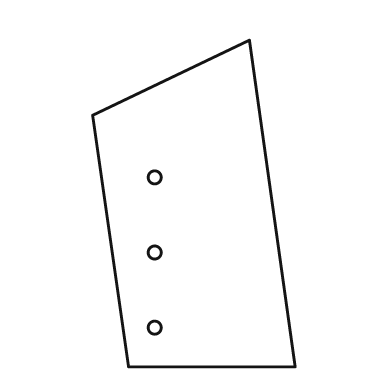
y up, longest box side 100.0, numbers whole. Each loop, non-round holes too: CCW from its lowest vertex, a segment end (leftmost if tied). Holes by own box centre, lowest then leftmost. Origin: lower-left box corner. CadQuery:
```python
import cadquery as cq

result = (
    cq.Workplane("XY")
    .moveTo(11.0, 0.0)
    .lineTo(62.0, 0.0)
    .lineTo(48.0, 100.0)
    .lineTo(0.0, 77.0)
    .close()
    .moveTo(19.0, 12.0)
    .circle(2.0)
    .moveTo(19.0, 35.0)
    .circle(2.0)
    .moveTo(19.0, 58.0)
    .circle(2.0)
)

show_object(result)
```